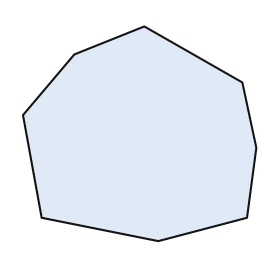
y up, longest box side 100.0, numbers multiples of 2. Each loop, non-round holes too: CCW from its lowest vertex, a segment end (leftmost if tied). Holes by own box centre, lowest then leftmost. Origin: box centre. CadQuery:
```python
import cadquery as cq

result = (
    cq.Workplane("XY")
    .moveTo(8.0, -46.0)
    .lineTo(46.0, -36.0)
    .lineTo(50.0, -6.0)
    .lineTo(44.0, 22.0)
    .lineTo(2.0, 46.0)
    .lineTo(-28.0, 34.0)
    .lineTo(-50.0, 8.0)
    .lineTo(-42.0, -36.0)
    .close()
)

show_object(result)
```